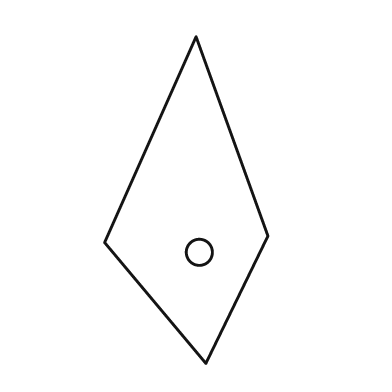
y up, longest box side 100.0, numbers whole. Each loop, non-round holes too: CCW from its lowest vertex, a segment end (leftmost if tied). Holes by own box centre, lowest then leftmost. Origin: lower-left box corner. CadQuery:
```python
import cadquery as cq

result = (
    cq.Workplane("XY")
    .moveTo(31.0, 0.0)
    .lineTo(50.0, 39.0)
    .lineTo(28.0, 100.0)
    .lineTo(0.0, 37.0)
    .close()
    .moveTo(29.0, 34.0)
    .circle(4.0)
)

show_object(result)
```